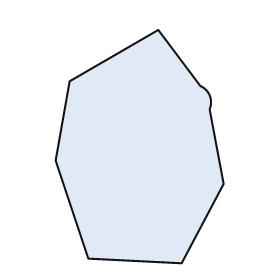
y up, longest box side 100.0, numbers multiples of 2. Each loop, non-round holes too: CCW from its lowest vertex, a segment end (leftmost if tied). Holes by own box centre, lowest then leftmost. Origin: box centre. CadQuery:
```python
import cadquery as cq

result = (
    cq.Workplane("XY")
    .moveTo(18.0, -50.0)
    .lineTo(36.0, -16.0)
    .lineTo(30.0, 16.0)
    .threePointArc((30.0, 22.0), (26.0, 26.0))
    .lineTo(8.0, 50.0)
    .lineTo(-30.0, 28.0)
    .lineTo(-36.0, -6.0)
    .lineTo(-22.0, -48.0)
    .close()
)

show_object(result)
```